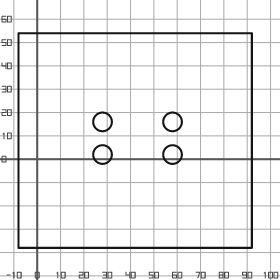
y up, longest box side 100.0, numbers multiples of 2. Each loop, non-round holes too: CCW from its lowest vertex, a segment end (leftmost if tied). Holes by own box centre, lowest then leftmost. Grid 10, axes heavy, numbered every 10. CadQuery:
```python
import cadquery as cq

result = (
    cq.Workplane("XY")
    .moveTo(-8.0, -38.0)
    .lineTo(92.0, -38.0)
    .lineTo(92.0, 54.0)
    .lineTo(-8.0, 54.0)
    .close()
    .moveTo(28.0, 2.0)
    .circle(4.0)
    .moveTo(58.0, 2.0)
    .circle(4.0)
    .moveTo(28.0, 16.0)
    .circle(4.0)
    .moveTo(58.0, 16.0)
    .circle(4.0)
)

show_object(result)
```